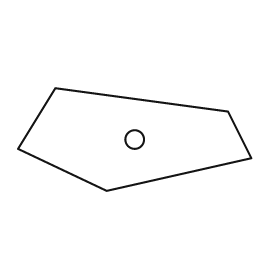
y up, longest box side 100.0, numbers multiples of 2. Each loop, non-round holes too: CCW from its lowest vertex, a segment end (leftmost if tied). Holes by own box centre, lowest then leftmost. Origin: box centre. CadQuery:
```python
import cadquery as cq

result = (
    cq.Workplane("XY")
    .moveTo(-12.0, -22.0)
    .lineTo(50.0, -8.0)
    .lineTo(40.0, 12.0)
    .lineTo(-34.0, 22.0)
    .lineTo(-50.0, -4.0)
    .close()
    .moveTo(0.0, 0.0)
    .circle(4.0)
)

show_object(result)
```